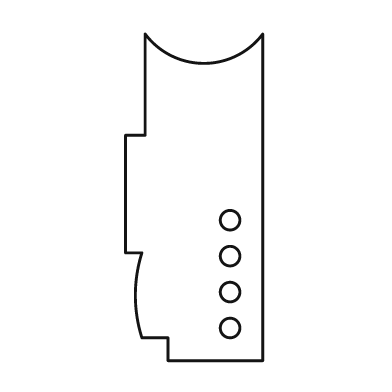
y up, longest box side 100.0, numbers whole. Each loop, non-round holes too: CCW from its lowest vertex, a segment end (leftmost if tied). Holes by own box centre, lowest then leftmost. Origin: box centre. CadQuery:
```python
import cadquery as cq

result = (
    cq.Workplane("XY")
    .moveTo(-8.0, -50.0)
    .lineTo(21.0, -50.0)
    .lineTo(21.0, 50.0)
    .threePointArc((3.0, 41.0), (-15.0, 50.0))
    .lineTo(-15.0, 19.0)
    .lineTo(-21.0, 19.0)
    .lineTo(-21.0, -17.0)
    .lineTo(-16.0, -17.0)
    .threePointArc((-18.0, -30.0), (-16.0, -43.0))
    .lineTo(-8.0, -43.0)
    .close()
    .moveTo(11.0, -40.0)
    .circle(3.0)
    .moveTo(11.0, -29.0)
    .circle(3.0)
    .moveTo(11.0, -18.0)
    .circle(3.0)
    .moveTo(11.0, -7.0)
    .circle(3.0)
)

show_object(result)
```